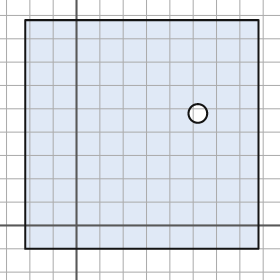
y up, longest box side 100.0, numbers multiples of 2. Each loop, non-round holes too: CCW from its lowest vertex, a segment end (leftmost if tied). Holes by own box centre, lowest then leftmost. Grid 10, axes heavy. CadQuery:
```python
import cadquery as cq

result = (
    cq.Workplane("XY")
    .moveTo(-22.0, -10.0)
    .lineTo(78.0, -10.0)
    .lineTo(78.0, 88.0)
    .lineTo(-22.0, 88.0)
    .close()
    .moveTo(52.0, 48.0)
    .circle(4.0)
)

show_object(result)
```